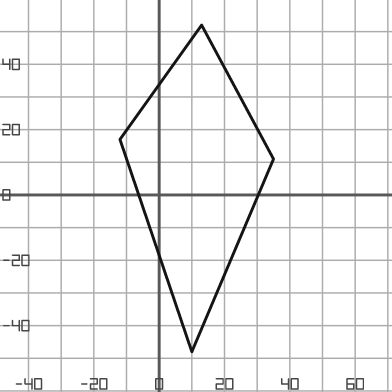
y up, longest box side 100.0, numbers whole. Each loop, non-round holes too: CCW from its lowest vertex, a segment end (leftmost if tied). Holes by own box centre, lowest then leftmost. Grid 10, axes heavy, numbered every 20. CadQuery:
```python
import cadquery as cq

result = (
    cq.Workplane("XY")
    .moveTo(10.0, -48.0)
    .lineTo(35.0, 11.0)
    .lineTo(13.0, 52.0)
    .lineTo(-12.0, 17.0)
    .close()
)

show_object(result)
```